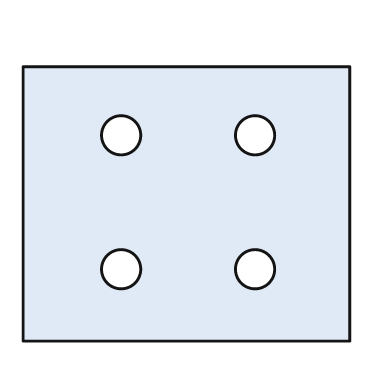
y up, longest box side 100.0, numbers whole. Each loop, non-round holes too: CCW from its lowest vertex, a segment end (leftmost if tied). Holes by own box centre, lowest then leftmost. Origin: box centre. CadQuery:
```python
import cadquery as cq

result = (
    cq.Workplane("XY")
    .moveTo(-50.0, -42.0)
    .lineTo(50.0, -42.0)
    .lineTo(50.0, 42.0)
    .lineTo(-50.0, 42.0)
    .close()
    .moveTo(-20.0, -20.0)
    .circle(6.0)
    .moveTo(21.0, -20.0)
    .circle(6.0)
    .moveTo(-20.0, 21.0)
    .circle(6.0)
    .moveTo(21.0, 21.0)
    .circle(6.0)
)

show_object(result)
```